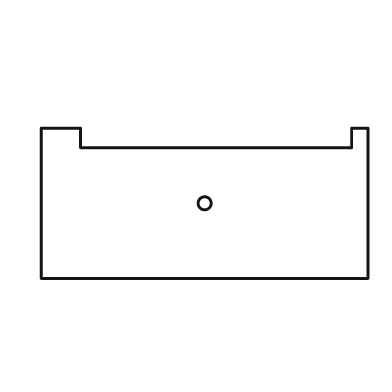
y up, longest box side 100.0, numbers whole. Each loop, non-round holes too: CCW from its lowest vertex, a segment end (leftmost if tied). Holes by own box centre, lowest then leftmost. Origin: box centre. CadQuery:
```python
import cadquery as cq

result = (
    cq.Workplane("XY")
    .moveTo(-50.0, -23.0)
    .lineTo(50.0, -23.0)
    .lineTo(50.0, 23.0)
    .lineTo(45.0, 23.0)
    .lineTo(45.0, 17.0)
    .lineTo(-38.0, 17.0)
    .lineTo(-38.0, 23.0)
    .lineTo(-50.0, 23.0)
    .close()
    .moveTo(0.0, 0.0)
    .circle(2.0)
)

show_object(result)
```